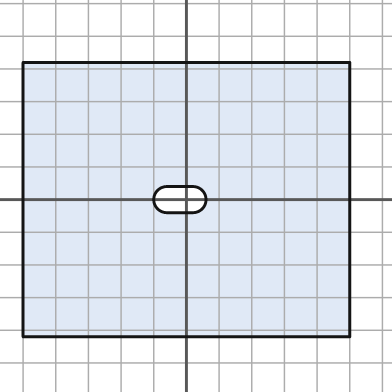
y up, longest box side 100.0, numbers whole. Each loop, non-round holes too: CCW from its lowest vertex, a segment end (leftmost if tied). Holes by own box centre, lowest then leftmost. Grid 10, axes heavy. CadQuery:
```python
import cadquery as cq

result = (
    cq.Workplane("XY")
    .moveTo(-50.0, -42.0)
    .lineTo(50.0, -42.0)
    .lineTo(50.0, 42.0)
    .lineTo(-50.0, 42.0)
    .close()
    .moveTo(-6.0, -4.0)
    .lineTo(2.0, -4.0)
    .threePointArc((6.0, 0.0), (2.0, 4.0))
    .lineTo(-6.0, 4.0)
    .threePointArc((-10.0, 0.0), (-6.0, -4.0))
    .close()
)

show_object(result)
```